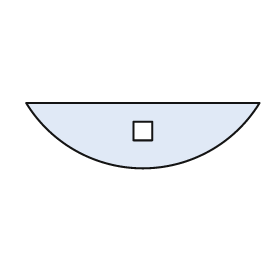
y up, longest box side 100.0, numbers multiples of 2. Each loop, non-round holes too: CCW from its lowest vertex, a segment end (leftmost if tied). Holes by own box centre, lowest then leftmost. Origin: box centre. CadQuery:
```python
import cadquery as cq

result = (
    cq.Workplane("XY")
    .moveTo(-50.0, 14.0)
    .threePointArc((0.0, -14.0), (50.0, 14.0))
    .close()
    .moveTo(-4.0, -2.0)
    .lineTo(4.0, -2.0)
    .lineTo(4.0, 6.0)
    .lineTo(-4.0, 6.0)
    .close()
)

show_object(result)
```